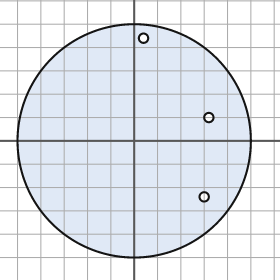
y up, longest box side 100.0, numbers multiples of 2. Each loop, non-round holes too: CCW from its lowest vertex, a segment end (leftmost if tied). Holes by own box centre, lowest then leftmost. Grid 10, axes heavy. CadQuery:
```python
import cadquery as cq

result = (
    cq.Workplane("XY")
    .moveTo(0.0, 0.0)
    .circle(50.0)
    .moveTo(30.0, -24.0)
    .circle(2.0)
    .moveTo(32.0, 10.0)
    .circle(2.0)
    .moveTo(4.0, 44.0)
    .circle(2.0)
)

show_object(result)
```